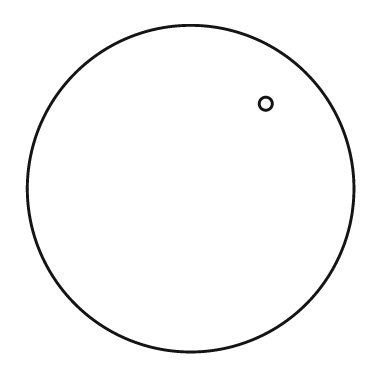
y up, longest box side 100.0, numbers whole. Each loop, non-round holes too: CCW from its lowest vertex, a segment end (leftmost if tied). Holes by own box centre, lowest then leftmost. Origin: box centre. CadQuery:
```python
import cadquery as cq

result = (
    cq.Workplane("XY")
    .moveTo(0.0, 0.0)
    .circle(50.0)
    .moveTo(23.0, 26.0)
    .circle(2.0)
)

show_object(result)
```